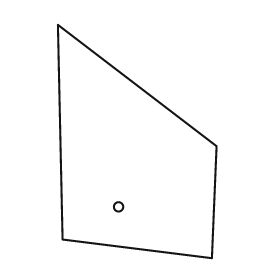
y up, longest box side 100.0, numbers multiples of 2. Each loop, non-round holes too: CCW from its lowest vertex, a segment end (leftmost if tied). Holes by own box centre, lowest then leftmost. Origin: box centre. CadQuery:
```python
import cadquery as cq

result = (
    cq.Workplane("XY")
    .moveTo(32.0, -50.0)
    .lineTo(34.0, -2.0)
    .lineTo(-34.0, 50.0)
    .lineTo(-32.0, -42.0)
    .close()
    .moveTo(-8.0, -28.0)
    .circle(2.0)
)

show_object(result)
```